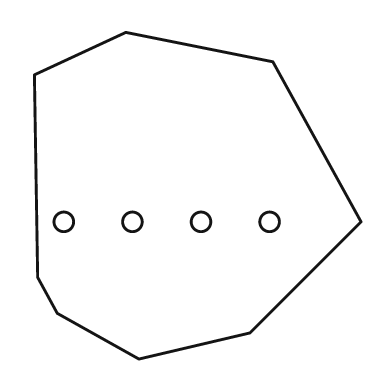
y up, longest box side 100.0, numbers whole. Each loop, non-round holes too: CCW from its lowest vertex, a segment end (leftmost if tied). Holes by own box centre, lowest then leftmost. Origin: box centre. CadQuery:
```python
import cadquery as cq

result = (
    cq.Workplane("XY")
    .moveTo(-18.0, -50.0)
    .lineTo(16.0, -42.0)
    .lineTo(50.0, -8.0)
    .lineTo(23.0, 41.0)
    .lineTo(-22.0, 50.0)
    .lineTo(-50.0, 37.0)
    .lineTo(-49.0, -25.0)
    .lineTo(-43.0, -36.0)
    .close()
    .moveTo(-41.0, -8.0)
    .circle(3.0)
    .moveTo(-20.0, -8.0)
    .circle(3.0)
    .moveTo(1.0, -8.0)
    .circle(3.0)
    .moveTo(22.0, -8.0)
    .circle(3.0)
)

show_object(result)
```